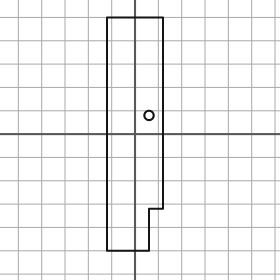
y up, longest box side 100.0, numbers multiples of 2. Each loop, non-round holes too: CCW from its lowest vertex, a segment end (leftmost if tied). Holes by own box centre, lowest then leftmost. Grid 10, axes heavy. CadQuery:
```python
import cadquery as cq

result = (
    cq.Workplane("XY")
    .moveTo(-12.0, -50.0)
    .lineTo(6.0, -50.0)
    .lineTo(6.0, -32.0)
    .lineTo(12.0, -32.0)
    .lineTo(12.0, 50.0)
    .lineTo(-12.0, 50.0)
    .close()
    .moveTo(6.0, 8.0)
    .circle(2.0)
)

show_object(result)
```